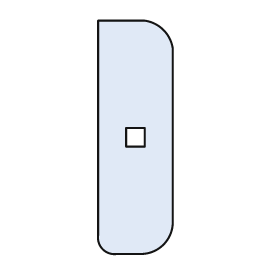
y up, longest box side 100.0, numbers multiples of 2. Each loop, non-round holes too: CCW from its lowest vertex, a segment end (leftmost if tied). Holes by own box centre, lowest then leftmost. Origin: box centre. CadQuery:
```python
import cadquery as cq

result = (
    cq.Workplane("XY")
    .moveTo(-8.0, -50.0)
    .lineTo(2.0, -50.0)
    .threePointArc((12.0, -46.0), (16.0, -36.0))
    .lineTo(16.0, 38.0)
    .threePointArc((12.0, 46.0), (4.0, 50.0))
    .lineTo(-16.0, 50.0)
    .lineTo(-16.0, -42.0)
    .threePointArc((-14.0, -48.0), (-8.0, -50.0))
    .close()
    .moveTo(-4.0, -4.0)
    .lineTo(4.0, -4.0)
    .lineTo(4.0, 4.0)
    .lineTo(-4.0, 4.0)
    .close()
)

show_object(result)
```